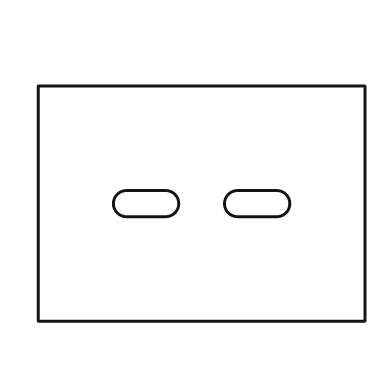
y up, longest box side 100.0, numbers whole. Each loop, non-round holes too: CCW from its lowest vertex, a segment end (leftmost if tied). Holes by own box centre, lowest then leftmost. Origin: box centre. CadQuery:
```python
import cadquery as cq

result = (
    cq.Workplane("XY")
    .moveTo(-50.0, -36.0)
    .lineTo(50.0, -36.0)
    .lineTo(50.0, 36.0)
    .lineTo(-50.0, 36.0)
    .close()
    .moveTo(-23.0, -4.0)
    .lineTo(-11.0, -4.0)
    .threePointArc((-7.0, 0.0), (-11.0, 4.0))
    .lineTo(-23.0, 4.0)
    .threePointArc((-27.0, 0.0), (-23.0, -4.0))
    .close()
    .moveTo(11.0, -4.0)
    .lineTo(23.0, -4.0)
    .threePointArc((27.0, 0.0), (23.0, 4.0))
    .lineTo(11.0, 4.0)
    .threePointArc((7.0, 0.0), (11.0, -4.0))
    .close()
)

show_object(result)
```